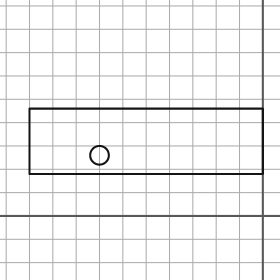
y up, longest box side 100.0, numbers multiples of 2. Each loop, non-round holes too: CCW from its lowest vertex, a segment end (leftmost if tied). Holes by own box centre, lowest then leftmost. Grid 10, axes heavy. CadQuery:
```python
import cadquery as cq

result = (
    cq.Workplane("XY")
    .moveTo(-100.0, 18.0)
    .lineTo(0.0, 18.0)
    .lineTo(0.0, 46.0)
    .lineTo(-100.0, 46.0)
    .close()
    .moveTo(-70.0, 26.0)
    .circle(4.0)
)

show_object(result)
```